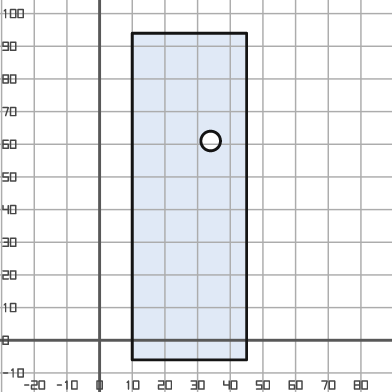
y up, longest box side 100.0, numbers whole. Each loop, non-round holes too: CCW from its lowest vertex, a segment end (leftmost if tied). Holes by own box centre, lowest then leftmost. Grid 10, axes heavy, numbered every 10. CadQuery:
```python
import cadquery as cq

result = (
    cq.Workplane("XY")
    .moveTo(10.0, -6.0)
    .lineTo(45.0, -6.0)
    .lineTo(45.0, 94.0)
    .lineTo(10.0, 94.0)
    .close()
    .moveTo(34.0, 61.0)
    .circle(3.0)
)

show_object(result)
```